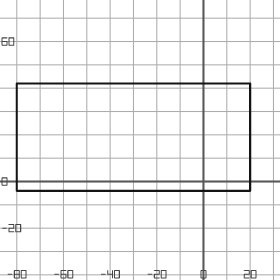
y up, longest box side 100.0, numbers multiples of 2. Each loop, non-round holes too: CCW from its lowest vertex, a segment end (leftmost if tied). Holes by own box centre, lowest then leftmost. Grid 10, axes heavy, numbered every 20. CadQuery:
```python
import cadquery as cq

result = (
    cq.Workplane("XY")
    .moveTo(-80.0, -4.0)
    .lineTo(20.0, -4.0)
    .lineTo(20.0, 42.0)
    .lineTo(-80.0, 42.0)
    .close()
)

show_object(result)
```